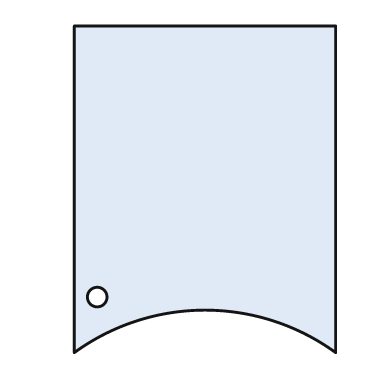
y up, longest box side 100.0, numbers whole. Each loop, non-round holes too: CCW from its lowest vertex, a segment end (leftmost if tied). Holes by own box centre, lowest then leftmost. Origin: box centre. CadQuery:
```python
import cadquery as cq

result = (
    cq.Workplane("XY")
    .moveTo(-40.0, -50.0)
    .threePointArc((0.0, -37.0), (40.0, -50.0))
    .lineTo(40.0, 50.0)
    .lineTo(-40.0, 50.0)
    .close()
    .moveTo(-33.0, -33.0)
    .circle(3.0)
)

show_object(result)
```